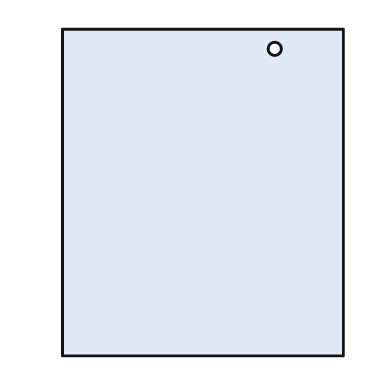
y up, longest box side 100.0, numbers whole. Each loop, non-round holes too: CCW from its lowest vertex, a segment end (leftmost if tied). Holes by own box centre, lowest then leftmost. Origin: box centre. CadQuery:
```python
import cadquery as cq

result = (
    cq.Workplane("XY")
    .moveTo(-43.0, -50.0)
    .lineTo(43.0, -50.0)
    .lineTo(43.0, 50.0)
    .lineTo(-43.0, 50.0)
    .close()
    .moveTo(22.0, 44.0)
    .circle(2.0)
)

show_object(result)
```